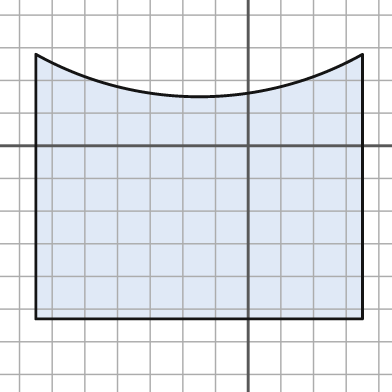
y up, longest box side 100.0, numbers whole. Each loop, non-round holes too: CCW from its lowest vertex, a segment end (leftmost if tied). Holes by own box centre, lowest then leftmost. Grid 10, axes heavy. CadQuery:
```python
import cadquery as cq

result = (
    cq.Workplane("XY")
    .moveTo(-65.0, -53.0)
    .lineTo(35.0, -53.0)
    .lineTo(35.0, 28.0)
    .threePointArc((-15.0, 15.0), (-65.0, 28.0))
    .close()
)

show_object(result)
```